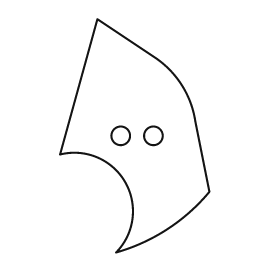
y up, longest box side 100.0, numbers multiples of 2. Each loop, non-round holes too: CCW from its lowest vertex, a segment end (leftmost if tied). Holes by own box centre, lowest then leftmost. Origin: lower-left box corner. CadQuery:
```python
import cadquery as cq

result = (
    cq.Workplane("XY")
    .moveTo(24.0, 0.0)
    .threePointArc((46.0, 10.0), (64.0, 26.0))
    .lineTo(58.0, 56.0)
    .threePointArc((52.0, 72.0), (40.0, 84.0))
    .lineTo(16.0, 100.0)
    .lineTo(0.0, 42.0)
    .threePointArc((28.0, 30.0), (24.0, 0.0))
    .close()
    .moveTo(26.0, 50.0)
    .circle(4.0)
    .moveTo(40.0, 50.0)
    .circle(4.0)
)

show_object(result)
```